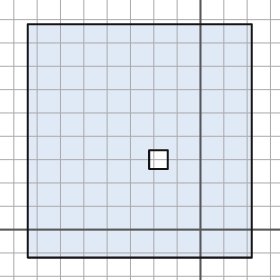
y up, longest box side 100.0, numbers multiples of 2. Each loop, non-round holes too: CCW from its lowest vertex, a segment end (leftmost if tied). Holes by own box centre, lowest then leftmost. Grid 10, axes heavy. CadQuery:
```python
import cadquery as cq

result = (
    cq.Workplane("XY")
    .moveTo(-74.0, -12.0)
    .lineTo(22.0, -12.0)
    .lineTo(22.0, 88.0)
    .lineTo(-74.0, 88.0)
    .close()
    .moveTo(-22.0, 26.0)
    .lineTo(-14.0, 26.0)
    .lineTo(-14.0, 34.0)
    .lineTo(-22.0, 34.0)
    .close()
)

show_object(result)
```